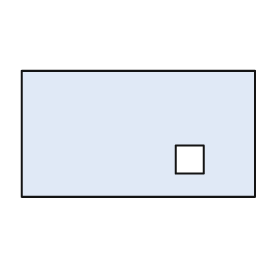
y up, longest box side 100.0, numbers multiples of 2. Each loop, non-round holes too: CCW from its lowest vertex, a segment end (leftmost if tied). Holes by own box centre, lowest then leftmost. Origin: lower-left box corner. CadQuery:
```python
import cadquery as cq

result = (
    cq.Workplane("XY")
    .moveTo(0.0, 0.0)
    .lineTo(100.0, 0.0)
    .lineTo(100.0, 54.0)
    .lineTo(0.0, 54.0)
    .close()
    .moveTo(66.0, 10.0)
    .lineTo(78.0, 10.0)
    .lineTo(78.0, 22.0)
    .lineTo(66.0, 22.0)
    .close()
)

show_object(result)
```